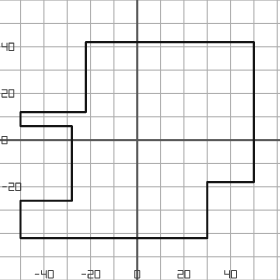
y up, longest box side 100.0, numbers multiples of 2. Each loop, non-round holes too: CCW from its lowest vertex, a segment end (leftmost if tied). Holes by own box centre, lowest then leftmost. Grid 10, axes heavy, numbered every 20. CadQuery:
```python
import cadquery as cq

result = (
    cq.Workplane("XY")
    .moveTo(-50.0, -42.0)
    .lineTo(30.0, -42.0)
    .lineTo(30.0, -18.0)
    .lineTo(50.0, -18.0)
    .lineTo(50.0, 42.0)
    .lineTo(-22.0, 42.0)
    .lineTo(-22.0, 12.0)
    .lineTo(-50.0, 12.0)
    .lineTo(-50.0, 6.0)
    .lineTo(-28.0, 6.0)
    .lineTo(-28.0, -26.0)
    .lineTo(-50.0, -26.0)
    .close()
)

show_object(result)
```